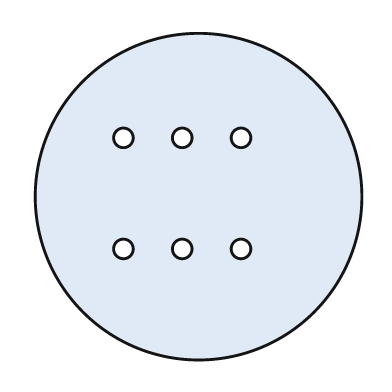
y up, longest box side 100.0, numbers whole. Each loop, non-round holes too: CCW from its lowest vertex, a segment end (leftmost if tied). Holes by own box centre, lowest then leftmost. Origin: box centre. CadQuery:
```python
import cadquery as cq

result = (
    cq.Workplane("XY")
    .moveTo(0.0, 0.0)
    .circle(50.0)
    .moveTo(-23.0, -16.0)
    .circle(3.0)
    .moveTo(-5.0, -16.0)
    .circle(3.0)
    .moveTo(13.0, -16.0)
    .circle(3.0)
    .moveTo(-23.0, 18.0)
    .circle(3.0)
    .moveTo(-5.0, 18.0)
    .circle(3.0)
    .moveTo(13.0, 18.0)
    .circle(3.0)
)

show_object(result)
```